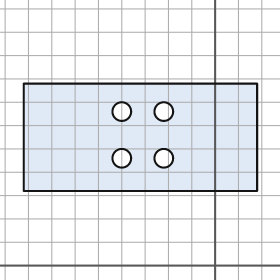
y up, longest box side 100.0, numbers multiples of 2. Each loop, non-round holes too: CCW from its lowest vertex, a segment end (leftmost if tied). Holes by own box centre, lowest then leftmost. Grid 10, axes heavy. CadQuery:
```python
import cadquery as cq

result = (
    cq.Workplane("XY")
    .moveTo(-82.0, 32.0)
    .lineTo(18.0, 32.0)
    .lineTo(18.0, 78.0)
    .lineTo(-82.0, 78.0)
    .close()
    .moveTo(-40.0, 46.0)
    .circle(4.0)
    .moveTo(-22.0, 46.0)
    .circle(4.0)
    .moveTo(-40.0, 66.0)
    .circle(4.0)
    .moveTo(-22.0, 66.0)
    .circle(4.0)
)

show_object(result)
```